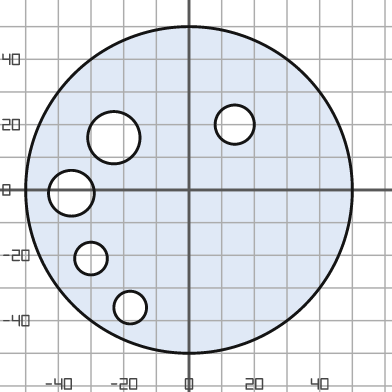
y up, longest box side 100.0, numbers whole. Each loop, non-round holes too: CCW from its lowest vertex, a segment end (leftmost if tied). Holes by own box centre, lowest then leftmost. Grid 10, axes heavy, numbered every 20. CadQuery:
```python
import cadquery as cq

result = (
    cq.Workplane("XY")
    .moveTo(0.0, 0.0)
    .circle(50.0)
    .moveTo(-18.0, -36.0)
    .circle(5.0)
    .moveTo(-30.0, -21.0)
    .circle(5.0)
    .moveTo(-36.0, -1.0)
    .circle(7.0)
    .moveTo(-23.0, 16.0)
    .circle(8.0)
    .moveTo(14.0, 20.0)
    .circle(6.0)
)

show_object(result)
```